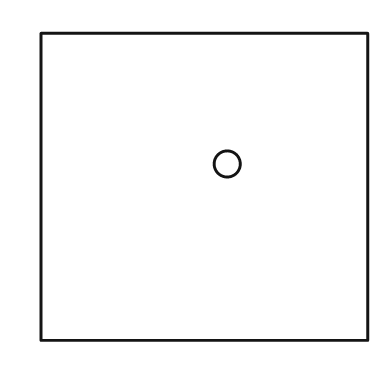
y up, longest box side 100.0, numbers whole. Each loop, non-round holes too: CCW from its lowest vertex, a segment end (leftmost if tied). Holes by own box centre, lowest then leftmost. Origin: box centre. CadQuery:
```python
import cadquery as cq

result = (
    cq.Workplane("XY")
    .moveTo(-50.0, -47.0)
    .lineTo(50.0, -47.0)
    .lineTo(50.0, 47.0)
    .lineTo(-50.0, 47.0)
    .close()
    .moveTo(7.0, 7.0)
    .circle(4.0)
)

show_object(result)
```